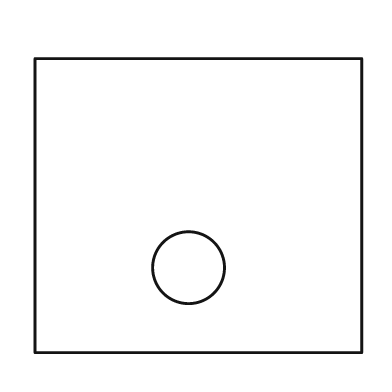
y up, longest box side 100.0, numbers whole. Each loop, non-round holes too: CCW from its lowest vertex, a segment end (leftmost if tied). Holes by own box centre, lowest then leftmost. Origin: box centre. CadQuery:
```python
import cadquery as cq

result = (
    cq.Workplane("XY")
    .moveTo(-50.0, -45.0)
    .lineTo(50.0, -45.0)
    .lineTo(50.0, 45.0)
    .lineTo(-50.0, 45.0)
    .close()
    .moveTo(-3.0, -19.0)
    .circle(11.0)
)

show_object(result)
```